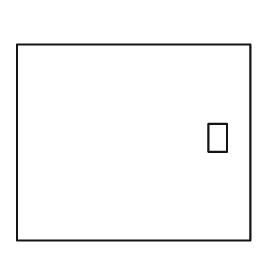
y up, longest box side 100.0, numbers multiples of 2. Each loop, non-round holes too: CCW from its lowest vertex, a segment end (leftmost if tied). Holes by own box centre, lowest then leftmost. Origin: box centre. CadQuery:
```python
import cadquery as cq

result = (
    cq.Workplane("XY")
    .moveTo(-50.0, -42.0)
    .lineTo(50.0, -42.0)
    .lineTo(50.0, 42.0)
    .lineTo(-50.0, 42.0)
    .close()
    .moveTo(32.0, -4.0)
    .lineTo(40.0, -4.0)
    .lineTo(40.0, 8.0)
    .lineTo(32.0, 8.0)
    .close()
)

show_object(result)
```